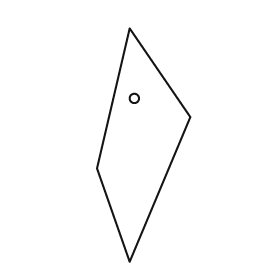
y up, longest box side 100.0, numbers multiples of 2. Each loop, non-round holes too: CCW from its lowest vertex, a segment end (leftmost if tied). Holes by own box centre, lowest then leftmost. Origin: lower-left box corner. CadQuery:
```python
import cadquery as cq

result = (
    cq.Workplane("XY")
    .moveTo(14.0, 0.0)
    .lineTo(40.0, 62.0)
    .lineTo(14.0, 100.0)
    .lineTo(0.0, 40.0)
    .close()
    .moveTo(16.0, 70.0)
    .circle(2.0)
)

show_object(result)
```